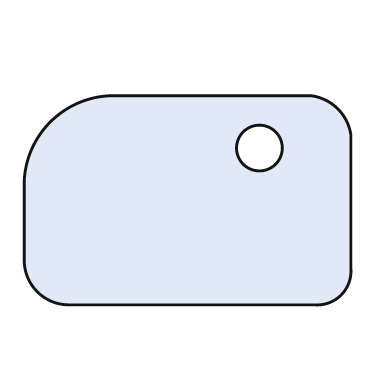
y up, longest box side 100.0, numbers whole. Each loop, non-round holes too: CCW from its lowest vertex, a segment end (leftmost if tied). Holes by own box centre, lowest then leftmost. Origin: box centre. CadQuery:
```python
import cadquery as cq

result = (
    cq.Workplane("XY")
    .moveTo(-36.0, -32.0)
    .lineTo(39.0, -32.0)
    .threePointArc((47.0, -29.0), (50.0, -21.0))
    .lineTo(50.0, 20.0)
    .threePointArc((46.0, 28.0), (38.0, 32.0))
    .lineTo(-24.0, 32.0)
    .threePointArc((-42.0, 24.0), (-50.0, 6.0))
    .lineTo(-50.0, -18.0)
    .threePointArc((-46.0, -28.0), (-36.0, -32.0))
    .close()
    .moveTo(22.0, 16.0)
    .circle(7.0)
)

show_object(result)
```